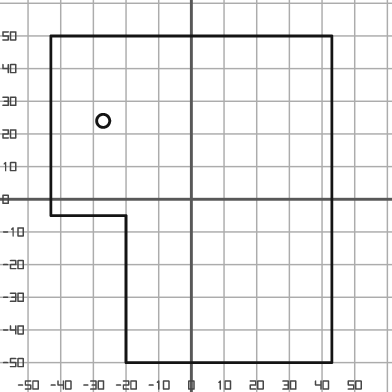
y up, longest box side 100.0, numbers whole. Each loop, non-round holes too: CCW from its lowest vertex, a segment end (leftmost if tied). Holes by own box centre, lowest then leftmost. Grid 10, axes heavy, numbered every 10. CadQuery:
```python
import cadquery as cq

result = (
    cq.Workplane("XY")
    .moveTo(-20.0, -50.0)
    .lineTo(43.0, -50.0)
    .lineTo(43.0, 50.0)
    .lineTo(-43.0, 50.0)
    .lineTo(-43.0, -5.0)
    .lineTo(-20.0, -5.0)
    .close()
    .moveTo(-27.0, 24.0)
    .circle(2.0)
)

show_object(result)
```